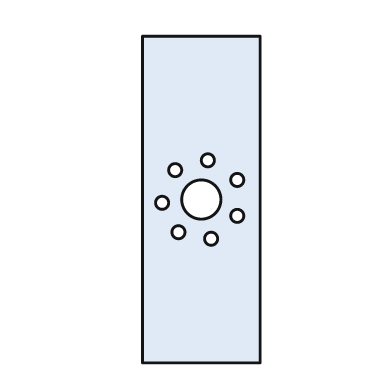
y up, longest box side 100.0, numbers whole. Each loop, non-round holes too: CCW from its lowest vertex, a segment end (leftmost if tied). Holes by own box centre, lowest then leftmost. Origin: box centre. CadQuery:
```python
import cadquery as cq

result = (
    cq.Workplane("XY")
    .moveTo(-18.0, -50.0)
    .lineTo(18.0, -50.0)
    .lineTo(18.0, 50.0)
    .lineTo(-18.0, 50.0)
    .close()
    .moveTo(3.0, -12.0)
    .circle(2.0)
    .moveTo(-7.0, -10.0)
    .circle(2.0)
    .moveTo(11.0, -5.0)
    .circle(2.0)
    .moveTo(-12.0, -1.0)
    .circle(2.0)
    .moveTo(0.0, 0.0)
    .circle(6.0)
    .moveTo(11.0, 6.0)
    .circle(2.0)
    .moveTo(-8.0, 9.0)
    .circle(2.0)
    .moveTo(2.0, 12.0)
    .circle(2.0)
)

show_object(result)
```